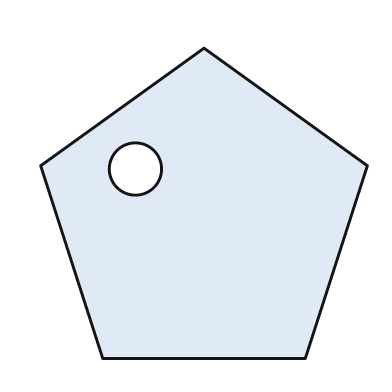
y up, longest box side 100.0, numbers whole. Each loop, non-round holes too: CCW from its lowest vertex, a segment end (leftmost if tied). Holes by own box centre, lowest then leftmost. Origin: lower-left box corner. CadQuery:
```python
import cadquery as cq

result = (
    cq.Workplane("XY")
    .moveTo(19.0, 0.0)
    .lineTo(81.0, 0.0)
    .lineTo(100.0, 59.0)
    .lineTo(50.0, 95.0)
    .lineTo(0.0, 59.0)
    .close()
    .moveTo(29.0, 58.0)
    .circle(8.0)
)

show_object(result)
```